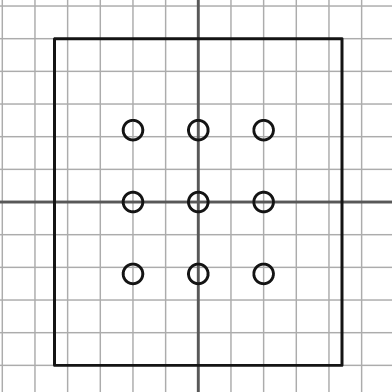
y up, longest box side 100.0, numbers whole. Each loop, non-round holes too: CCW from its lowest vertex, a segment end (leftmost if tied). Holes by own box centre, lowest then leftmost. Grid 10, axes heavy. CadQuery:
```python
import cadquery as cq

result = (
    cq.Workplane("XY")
    .moveTo(-44.0, -50.0)
    .lineTo(44.0, -50.0)
    .lineTo(44.0, 50.0)
    .lineTo(-44.0, 50.0)
    .close()
    .moveTo(-20.0, -22.0)
    .circle(3.0)
    .moveTo(0.0, -22.0)
    .circle(3.0)
    .moveTo(20.0, -22.0)
    .circle(3.0)
    .moveTo(-20.0, 0.0)
    .circle(3.0)
    .moveTo(0.0, 0.0)
    .circle(3.0)
    .moveTo(20.0, 0.0)
    .circle(3.0)
    .moveTo(-20.0, 22.0)
    .circle(3.0)
    .moveTo(0.0, 22.0)
    .circle(3.0)
    .moveTo(20.0, 22.0)
    .circle(3.0)
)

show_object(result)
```